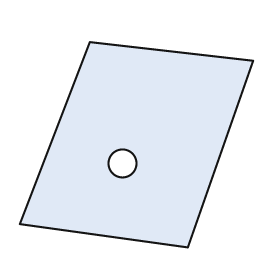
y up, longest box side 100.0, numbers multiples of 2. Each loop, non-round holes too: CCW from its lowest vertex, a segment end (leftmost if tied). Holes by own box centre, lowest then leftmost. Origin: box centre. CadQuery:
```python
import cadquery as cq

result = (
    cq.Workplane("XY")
    .moveTo(22.0, -44.0)
    .lineTo(50.0, 36.0)
    .lineTo(-20.0, 44.0)
    .lineTo(-50.0, -34.0)
    .close()
    .moveTo(-6.0, -8.0)
    .circle(6.0)
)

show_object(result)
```